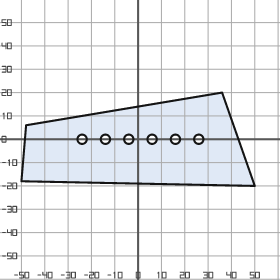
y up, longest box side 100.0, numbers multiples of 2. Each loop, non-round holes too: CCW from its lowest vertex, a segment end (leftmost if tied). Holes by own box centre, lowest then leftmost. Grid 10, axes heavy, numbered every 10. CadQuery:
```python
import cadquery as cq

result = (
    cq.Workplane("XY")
    .moveTo(50.0, -20.0)
    .lineTo(36.0, 20.0)
    .lineTo(-48.0, 6.0)
    .lineTo(-50.0, -18.0)
    .close()
    .moveTo(-24.0, 0.0)
    .circle(2.0)
    .moveTo(-14.0, 0.0)
    .circle(2.0)
    .moveTo(-4.0, 0.0)
    .circle(2.0)
    .moveTo(6.0, 0.0)
    .circle(2.0)
    .moveTo(16.0, 0.0)
    .circle(2.0)
    .moveTo(26.0, 0.0)
    .circle(2.0)
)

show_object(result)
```